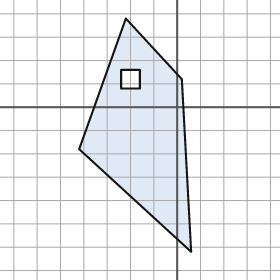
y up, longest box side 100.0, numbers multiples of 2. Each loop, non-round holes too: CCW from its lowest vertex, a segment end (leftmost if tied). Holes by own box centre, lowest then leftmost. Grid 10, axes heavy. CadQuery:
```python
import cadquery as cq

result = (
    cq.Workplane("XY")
    .moveTo(6.0, -62.0)
    .lineTo(2.0, 12.0)
    .lineTo(-22.0, 38.0)
    .lineTo(-42.0, -18.0)
    .close()
    .moveTo(-24.0, 8.0)
    .lineTo(-16.0, 8.0)
    .lineTo(-16.0, 16.0)
    .lineTo(-24.0, 16.0)
    .close()
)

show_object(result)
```